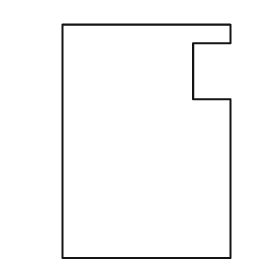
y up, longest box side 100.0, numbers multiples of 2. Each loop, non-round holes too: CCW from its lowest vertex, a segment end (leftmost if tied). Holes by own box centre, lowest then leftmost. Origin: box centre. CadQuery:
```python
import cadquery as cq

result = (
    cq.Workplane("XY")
    .moveTo(-36.0, -50.0)
    .lineTo(36.0, -50.0)
    .lineTo(36.0, 18.0)
    .lineTo(20.0, 18.0)
    .lineTo(20.0, 42.0)
    .lineTo(36.0, 42.0)
    .lineTo(36.0, 50.0)
    .lineTo(-36.0, 50.0)
    .close()
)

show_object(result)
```